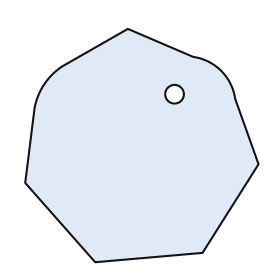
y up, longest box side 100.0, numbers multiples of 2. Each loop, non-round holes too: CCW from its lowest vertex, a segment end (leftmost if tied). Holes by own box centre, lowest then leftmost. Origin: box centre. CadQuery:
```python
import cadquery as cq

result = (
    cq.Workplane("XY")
    .moveTo(-20.0, -50.0)
    .lineTo(26.0, -46.0)
    .lineTo(50.0, -8.0)
    .lineTo(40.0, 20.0)
    .threePointArc((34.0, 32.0), (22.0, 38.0))
    .lineTo(-6.0, 50.0)
    .lineTo(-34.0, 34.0)
    .threePointArc((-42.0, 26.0), (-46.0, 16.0))
    .lineTo(-50.0, -16.0)
    .close()
    .moveTo(14.0, 22.0)
    .circle(4.0)
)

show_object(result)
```